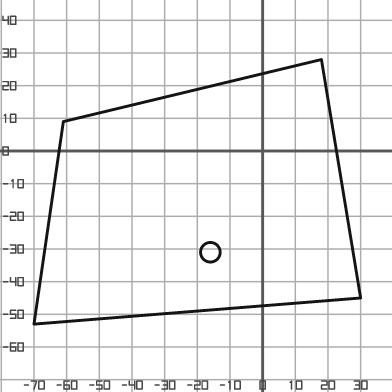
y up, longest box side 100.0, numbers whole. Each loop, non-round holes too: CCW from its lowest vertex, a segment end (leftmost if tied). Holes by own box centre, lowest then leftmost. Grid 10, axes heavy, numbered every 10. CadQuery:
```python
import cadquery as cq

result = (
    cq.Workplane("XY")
    .moveTo(-70.0, -53.0)
    .lineTo(30.0, -45.0)
    .lineTo(18.0, 28.0)
    .lineTo(-61.0, 9.0)
    .close()
    .moveTo(-16.0, -31.0)
    .circle(3.0)
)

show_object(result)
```